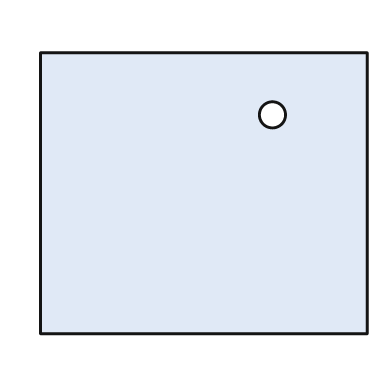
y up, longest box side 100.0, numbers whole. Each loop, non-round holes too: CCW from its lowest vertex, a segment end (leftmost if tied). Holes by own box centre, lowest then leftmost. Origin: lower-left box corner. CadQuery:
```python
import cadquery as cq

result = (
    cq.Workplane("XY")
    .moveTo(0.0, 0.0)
    .lineTo(100.0, 0.0)
    .lineTo(100.0, 86.0)
    .lineTo(0.0, 86.0)
    .close()
    .moveTo(71.0, 67.0)
    .circle(4.0)
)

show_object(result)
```